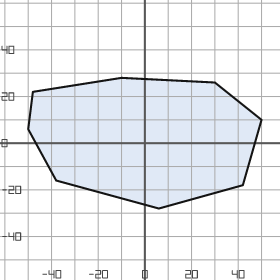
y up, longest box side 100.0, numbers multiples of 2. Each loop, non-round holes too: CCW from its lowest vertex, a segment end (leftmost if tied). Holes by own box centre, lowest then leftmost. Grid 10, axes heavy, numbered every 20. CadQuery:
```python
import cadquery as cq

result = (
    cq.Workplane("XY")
    .moveTo(6.0, -28.0)
    .lineTo(42.0, -18.0)
    .lineTo(50.0, 10.0)
    .lineTo(30.0, 26.0)
    .lineTo(-10.0, 28.0)
    .lineTo(-48.0, 22.0)
    .lineTo(-50.0, 6.0)
    .lineTo(-38.0, -16.0)
    .close()
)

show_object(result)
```